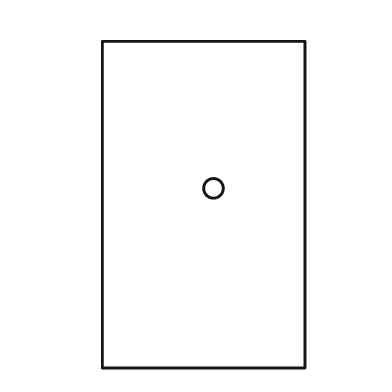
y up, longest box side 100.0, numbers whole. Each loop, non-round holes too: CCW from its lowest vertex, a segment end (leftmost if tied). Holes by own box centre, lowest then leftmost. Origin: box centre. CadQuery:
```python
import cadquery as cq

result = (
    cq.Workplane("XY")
    .moveTo(-31.0, -50.0)
    .lineTo(31.0, -50.0)
    .lineTo(31.0, 50.0)
    .lineTo(-31.0, 50.0)
    .close()
    .moveTo(3.0, 5.0)
    .circle(3.0)
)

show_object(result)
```